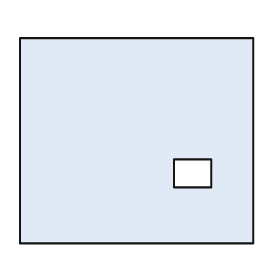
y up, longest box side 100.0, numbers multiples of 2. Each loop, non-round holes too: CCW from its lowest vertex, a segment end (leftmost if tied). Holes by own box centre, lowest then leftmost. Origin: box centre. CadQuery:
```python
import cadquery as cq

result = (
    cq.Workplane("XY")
    .moveTo(-50.0, -44.0)
    .lineTo(50.0, -44.0)
    .lineTo(50.0, 44.0)
    .lineTo(-50.0, 44.0)
    .close()
    .moveTo(16.0, -20.0)
    .lineTo(32.0, -20.0)
    .lineTo(32.0, -8.0)
    .lineTo(16.0, -8.0)
    .close()
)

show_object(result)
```